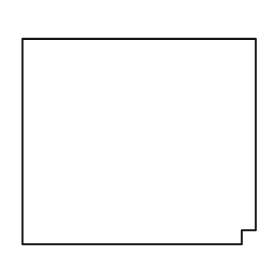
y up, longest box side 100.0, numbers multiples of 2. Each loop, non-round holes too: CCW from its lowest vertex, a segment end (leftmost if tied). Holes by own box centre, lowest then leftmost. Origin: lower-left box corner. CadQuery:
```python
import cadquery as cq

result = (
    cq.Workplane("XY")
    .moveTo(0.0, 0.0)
    .lineTo(94.0, 0.0)
    .lineTo(94.0, 6.0)
    .lineTo(100.0, 6.0)
    .lineTo(100.0, 88.0)
    .lineTo(0.0, 88.0)
    .close()
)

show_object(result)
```